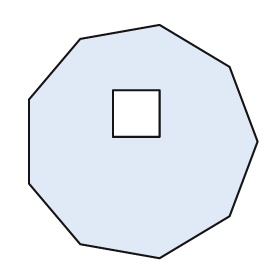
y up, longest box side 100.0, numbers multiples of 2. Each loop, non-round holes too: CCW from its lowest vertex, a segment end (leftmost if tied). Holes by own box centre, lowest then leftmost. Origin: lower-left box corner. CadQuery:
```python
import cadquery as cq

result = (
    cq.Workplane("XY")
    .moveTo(56.0, 0.0)
    .lineTo(86.0, 18.0)
    .lineTo(98.0, 50.0)
    .lineTo(86.0, 82.0)
    .lineTo(56.0, 100.0)
    .lineTo(22.0, 94.0)
    .lineTo(0.0, 68.0)
    .lineTo(0.0, 32.0)
    .lineTo(22.0, 6.0)
    .close()
    .moveTo(36.0, 52.0)
    .lineTo(56.0, 52.0)
    .lineTo(56.0, 72.0)
    .lineTo(36.0, 72.0)
    .close()
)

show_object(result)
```